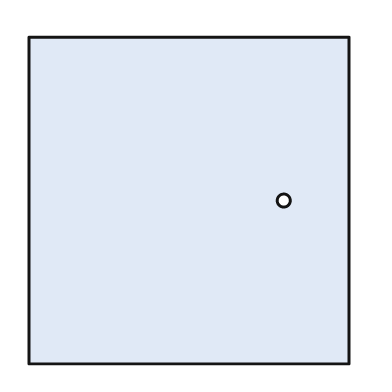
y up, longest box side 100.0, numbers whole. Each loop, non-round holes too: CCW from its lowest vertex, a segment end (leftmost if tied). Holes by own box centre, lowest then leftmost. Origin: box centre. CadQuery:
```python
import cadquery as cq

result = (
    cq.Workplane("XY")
    .moveTo(-49.0, -50.0)
    .lineTo(49.0, -50.0)
    .lineTo(49.0, 50.0)
    .lineTo(-49.0, 50.0)
    .close()
    .moveTo(29.0, 0.0)
    .circle(2.0)
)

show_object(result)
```